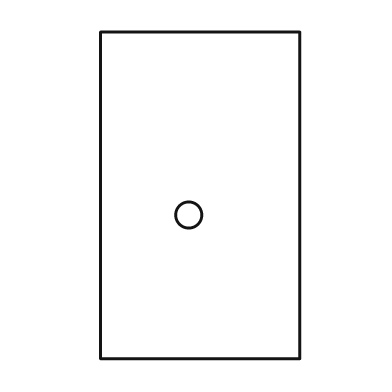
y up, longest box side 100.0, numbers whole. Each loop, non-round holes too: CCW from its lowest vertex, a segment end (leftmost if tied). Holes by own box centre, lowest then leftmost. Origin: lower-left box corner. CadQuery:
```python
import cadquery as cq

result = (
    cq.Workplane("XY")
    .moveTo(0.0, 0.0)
    .lineTo(61.0, 0.0)
    .lineTo(61.0, 100.0)
    .lineTo(0.0, 100.0)
    .close()
    .moveTo(27.0, 44.0)
    .circle(4.0)
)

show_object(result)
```